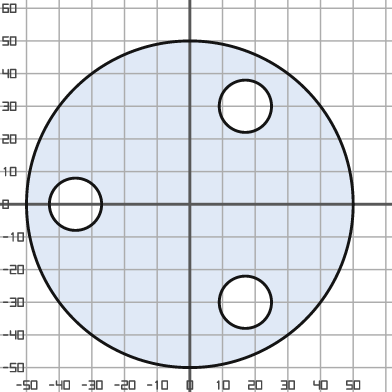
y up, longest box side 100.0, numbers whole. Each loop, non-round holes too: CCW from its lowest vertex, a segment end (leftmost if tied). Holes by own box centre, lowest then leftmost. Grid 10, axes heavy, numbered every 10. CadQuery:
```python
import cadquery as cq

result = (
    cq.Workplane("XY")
    .moveTo(0.0, 0.0)
    .circle(50.0)
    .moveTo(17.0, -30.0)
    .circle(8.0)
    .moveTo(-35.0, 0.0)
    .circle(8.0)
    .moveTo(17.0, 30.0)
    .circle(8.0)
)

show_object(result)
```